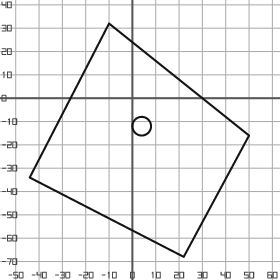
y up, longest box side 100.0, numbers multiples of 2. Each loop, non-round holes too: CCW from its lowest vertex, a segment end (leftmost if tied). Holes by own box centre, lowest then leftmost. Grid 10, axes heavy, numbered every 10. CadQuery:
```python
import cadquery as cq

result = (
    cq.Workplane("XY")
    .moveTo(22.0, -68.0)
    .lineTo(50.0, -16.0)
    .lineTo(-10.0, 32.0)
    .lineTo(-44.0, -34.0)
    .close()
    .moveTo(4.0, -12.0)
    .circle(4.0)
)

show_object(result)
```